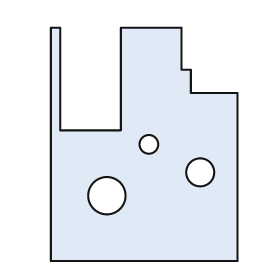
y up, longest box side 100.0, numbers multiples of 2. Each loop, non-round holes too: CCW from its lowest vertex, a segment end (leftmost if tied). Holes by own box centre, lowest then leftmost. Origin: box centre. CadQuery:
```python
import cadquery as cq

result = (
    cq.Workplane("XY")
    .moveTo(-40.0, -50.0)
    .lineTo(40.0, -50.0)
    .lineTo(40.0, 22.0)
    .lineTo(20.0, 22.0)
    .lineTo(20.0, 32.0)
    .lineTo(16.0, 32.0)
    .lineTo(16.0, 50.0)
    .lineTo(-10.0, 50.0)
    .lineTo(-10.0, 6.0)
    .lineTo(-36.0, 6.0)
    .lineTo(-36.0, 50.0)
    .lineTo(-40.0, 50.0)
    .close()
    .moveTo(-16.0, -22.0)
    .circle(8.0)
    .moveTo(24.0, -12.0)
    .circle(6.0)
    .moveTo(2.0, 0.0)
    .circle(4.0)
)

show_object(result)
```